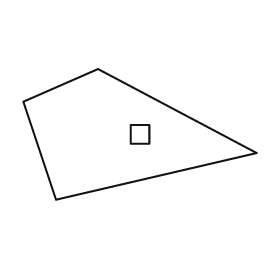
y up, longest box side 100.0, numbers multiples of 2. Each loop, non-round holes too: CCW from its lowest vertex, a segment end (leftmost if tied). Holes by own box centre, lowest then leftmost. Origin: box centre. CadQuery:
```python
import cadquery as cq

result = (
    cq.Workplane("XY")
    .moveTo(-36.0, -28.0)
    .lineTo(50.0, -8.0)
    .lineTo(-18.0, 28.0)
    .lineTo(-50.0, 14.0)
    .close()
    .moveTo(-4.0, -4.0)
    .lineTo(4.0, -4.0)
    .lineTo(4.0, 4.0)
    .lineTo(-4.0, 4.0)
    .close()
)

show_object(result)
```